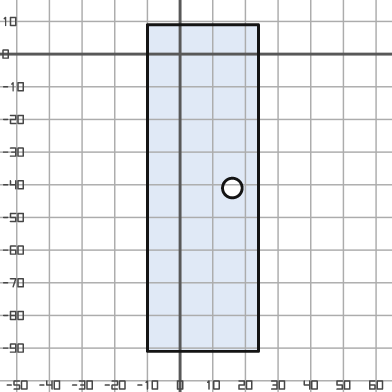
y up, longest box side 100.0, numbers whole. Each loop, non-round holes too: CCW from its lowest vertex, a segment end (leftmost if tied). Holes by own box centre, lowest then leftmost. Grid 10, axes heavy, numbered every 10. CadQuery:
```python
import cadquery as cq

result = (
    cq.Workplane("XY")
    .moveTo(-10.0, -91.0)
    .lineTo(24.0, -91.0)
    .lineTo(24.0, 9.0)
    .lineTo(-10.0, 9.0)
    .close()
    .moveTo(16.0, -41.0)
    .circle(3.0)
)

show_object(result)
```